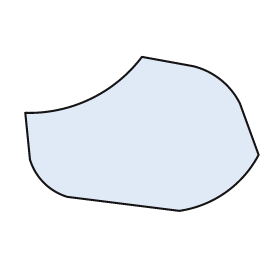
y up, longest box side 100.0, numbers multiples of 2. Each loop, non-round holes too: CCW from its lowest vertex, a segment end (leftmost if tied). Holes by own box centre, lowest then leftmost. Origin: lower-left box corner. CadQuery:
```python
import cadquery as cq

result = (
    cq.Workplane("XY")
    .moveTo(66.0, 0.0)
    .threePointArc((86.0, 8.0), (100.0, 24.0))
    .lineTo(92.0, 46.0)
    .threePointArc((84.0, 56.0), (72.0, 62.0))
    .lineTo(50.0, 66.0)
    .threePointArc((28.0, 48.0), (0.0, 42.0))
    .lineTo(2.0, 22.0)
    .threePointArc((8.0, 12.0), (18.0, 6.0))
    .close()
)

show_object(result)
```